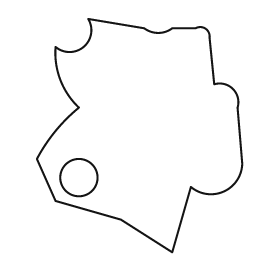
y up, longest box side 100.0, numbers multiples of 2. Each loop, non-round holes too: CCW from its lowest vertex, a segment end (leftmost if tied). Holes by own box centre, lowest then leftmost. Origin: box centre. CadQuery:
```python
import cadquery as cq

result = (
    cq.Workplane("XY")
    .moveTo(14.0, -50.0)
    .lineTo(22.0, -22.0)
    .threePointArc((36.0, -24.0), (44.0, -12.0))
    .lineTo(42.0, 12.0)
    .threePointArc((40.0, 20.0), (32.0, 22.0))
    .lineTo(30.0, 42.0)
    .threePointArc((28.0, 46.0), (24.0, 46.0))
    .lineTo(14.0, 46.0)
    .threePointArc((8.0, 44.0), (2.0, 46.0))
    .lineTo(-22.0, 50.0)
    .threePointArc((-24.0, 38.0), (-36.0, 38.0))
    .threePointArc((-34.0, 24.0), (-26.0, 12.0))
    .threePointArc((-36.0, 2.0), (-44.0, -10.0))
    .lineTo(-36.0, -28.0)
    .lineTo(-8.0, -36.0)
    .close()
    .moveTo(-26.0, -18.0)
    .circle(8.0)
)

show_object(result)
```